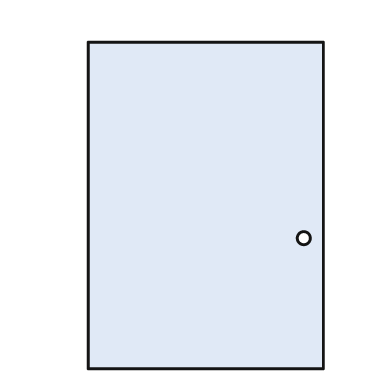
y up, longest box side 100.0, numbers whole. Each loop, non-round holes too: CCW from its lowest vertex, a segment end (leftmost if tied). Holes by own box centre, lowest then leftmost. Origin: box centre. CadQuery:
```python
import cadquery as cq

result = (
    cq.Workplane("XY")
    .moveTo(-36.0, -50.0)
    .lineTo(36.0, -50.0)
    .lineTo(36.0, 50.0)
    .lineTo(-36.0, 50.0)
    .close()
    .moveTo(30.0, -10.0)
    .circle(2.0)
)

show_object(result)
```